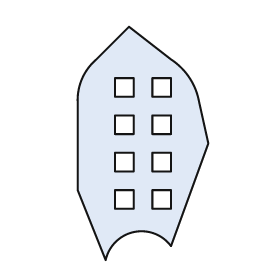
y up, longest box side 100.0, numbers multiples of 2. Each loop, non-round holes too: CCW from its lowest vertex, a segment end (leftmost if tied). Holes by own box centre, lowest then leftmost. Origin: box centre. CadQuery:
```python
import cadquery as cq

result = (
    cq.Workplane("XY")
    .moveTo(-16.0, -50.0)
    .threePointArc((-4.0, -38.0), (12.0, -44.0))
    .lineTo(28.0, 0.0)
    .lineTo(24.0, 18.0)
    .threePointArc((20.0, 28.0), (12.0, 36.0))
    .lineTo(-6.0, 50.0)
    .lineTo(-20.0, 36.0)
    .threePointArc((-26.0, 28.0), (-28.0, 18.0))
    .lineTo(-28.0, -20.0)
    .close()
    .moveTo(-12.0, -28.0)
    .lineTo(-4.0, -28.0)
    .lineTo(-4.0, -20.0)
    .lineTo(-12.0, -20.0)
    .close()
    .moveTo(4.0, -28.0)
    .lineTo(12.0, -28.0)
    .lineTo(12.0, -20.0)
    .lineTo(4.0, -20.0)
    .close()
    .moveTo(-12.0, -12.0)
    .lineTo(-4.0, -12.0)
    .lineTo(-4.0, -4.0)
    .lineTo(-12.0, -4.0)
    .close()
    .moveTo(4.0, -12.0)
    .lineTo(12.0, -12.0)
    .lineTo(12.0, -4.0)
    .lineTo(4.0, -4.0)
    .close()
    .moveTo(-12.0, 4.0)
    .lineTo(-4.0, 4.0)
    .lineTo(-4.0, 12.0)
    .lineTo(-12.0, 12.0)
    .close()
    .moveTo(4.0, 4.0)
    .lineTo(12.0, 4.0)
    .lineTo(12.0, 12.0)
    .lineTo(4.0, 12.0)
    .close()
    .moveTo(-12.0, 20.0)
    .lineTo(-4.0, 20.0)
    .lineTo(-4.0, 28.0)
    .lineTo(-12.0, 28.0)
    .close()
    .moveTo(4.0, 20.0)
    .lineTo(12.0, 20.0)
    .lineTo(12.0, 28.0)
    .lineTo(4.0, 28.0)
    .close()
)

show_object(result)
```